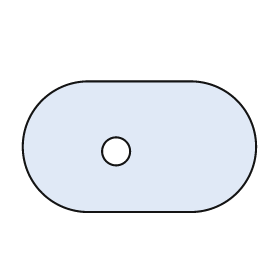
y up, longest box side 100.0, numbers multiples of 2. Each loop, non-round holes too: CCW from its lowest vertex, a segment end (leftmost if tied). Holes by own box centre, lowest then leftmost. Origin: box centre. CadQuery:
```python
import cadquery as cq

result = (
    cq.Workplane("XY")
    .moveTo(-22.0, -28.0)
    .lineTo(22.0, -28.0)
    .threePointArc((50.0, 0.0), (22.0, 28.0))
    .lineTo(-22.0, 28.0)
    .threePointArc((-50.0, 0.0), (-22.0, -28.0))
    .close()
    .moveTo(-10.0, -2.0)
    .circle(6.0)
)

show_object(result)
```